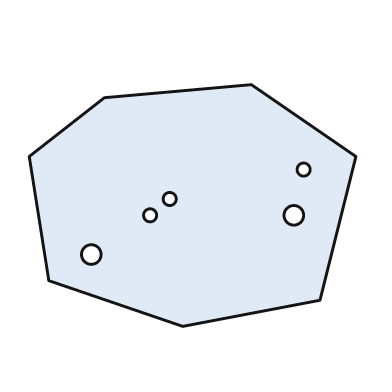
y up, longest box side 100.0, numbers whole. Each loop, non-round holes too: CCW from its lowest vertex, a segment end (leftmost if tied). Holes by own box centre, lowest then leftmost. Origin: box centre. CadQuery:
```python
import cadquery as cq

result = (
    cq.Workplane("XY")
    .moveTo(-3.0, -37.0)
    .lineTo(39.0, -29.0)
    .lineTo(50.0, 15.0)
    .lineTo(18.0, 37.0)
    .lineTo(-27.0, 33.0)
    .lineTo(-50.0, 15.0)
    .lineTo(-44.0, -23.0)
    .close()
    .moveTo(-31.0, -15.0)
    .circle(3.0)
    .moveTo(-13.0, -3.0)
    .circle(2.0)
    .moveTo(31.0, -3.0)
    .circle(3.0)
    .moveTo(-7.0, 2.0)
    .circle(2.0)
    .moveTo(34.0, 11.0)
    .circle(2.0)
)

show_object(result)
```